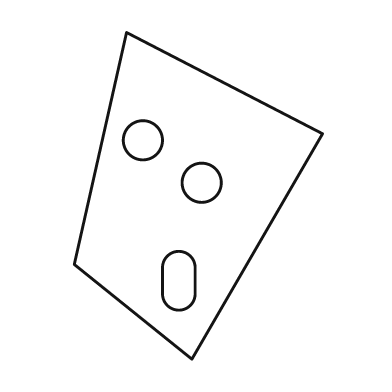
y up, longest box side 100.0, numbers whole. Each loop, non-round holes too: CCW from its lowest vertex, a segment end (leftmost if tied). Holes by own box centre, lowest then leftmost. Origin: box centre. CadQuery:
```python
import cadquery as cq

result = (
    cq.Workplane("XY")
    .moveTo(-2.0, -50.0)
    .lineTo(38.0, 19.0)
    .lineTo(-22.0, 50.0)
    .lineTo(-38.0, -21.0)
    .close()
    .moveTo(-11.0, -30.0)
    .threePointArc((-6.0, -35.0), (-1.0, -30.0))
    .lineTo(-1.0, -22.0)
    .threePointArc((-6.0, -17.0), (-11.0, -22.0))
    .close()
    .moveTo(1.0, 4.0)
    .circle(6.0)
    .moveTo(-17.0, 17.0)
    .circle(6.0)
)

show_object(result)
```